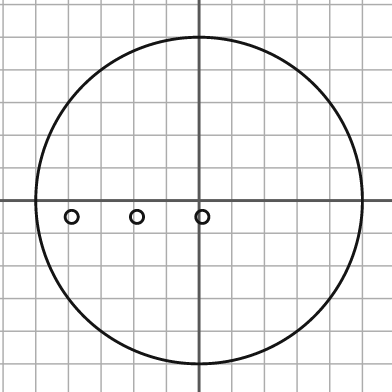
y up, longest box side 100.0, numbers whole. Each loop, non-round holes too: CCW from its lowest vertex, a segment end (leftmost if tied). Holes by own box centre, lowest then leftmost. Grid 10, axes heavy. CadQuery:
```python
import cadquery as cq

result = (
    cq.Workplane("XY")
    .moveTo(0.0, 0.0)
    .circle(50.0)
    .moveTo(-39.0, -5.0)
    .circle(2.0)
    .moveTo(-19.0, -5.0)
    .circle(2.0)
    .moveTo(1.0, -5.0)
    .circle(2.0)
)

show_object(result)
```